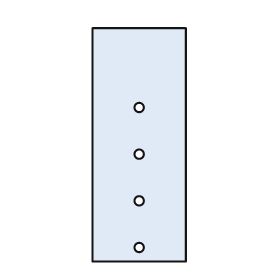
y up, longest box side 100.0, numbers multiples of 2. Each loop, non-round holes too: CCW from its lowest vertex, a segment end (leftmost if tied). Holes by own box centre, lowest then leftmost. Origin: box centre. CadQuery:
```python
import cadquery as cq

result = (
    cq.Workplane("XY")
    .moveTo(-20.0, -50.0)
    .lineTo(20.0, -50.0)
    .lineTo(20.0, 50.0)
    .lineTo(-20.0, 50.0)
    .close()
    .moveTo(0.0, -44.0)
    .circle(2.0)
    .moveTo(0.0, -24.0)
    .circle(2.0)
    .moveTo(0.0, -4.0)
    .circle(2.0)
    .moveTo(0.0, 16.0)
    .circle(2.0)
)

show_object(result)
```